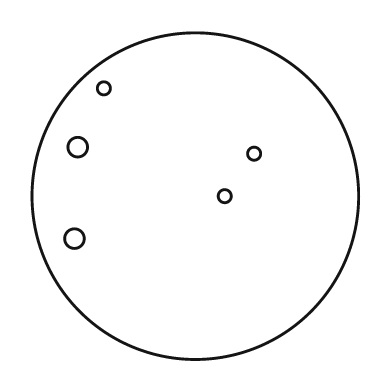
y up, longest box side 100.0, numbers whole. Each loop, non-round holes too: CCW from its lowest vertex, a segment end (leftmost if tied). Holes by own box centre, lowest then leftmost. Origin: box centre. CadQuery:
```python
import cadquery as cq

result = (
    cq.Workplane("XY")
    .moveTo(0.0, 0.0)
    .circle(50.0)
    .moveTo(-37.0, -13.0)
    .circle(3.0)
    .moveTo(9.0, 0.0)
    .circle(2.0)
    .moveTo(18.0, 13.0)
    .circle(2.0)
    .moveTo(-36.0, 15.0)
    .circle(3.0)
    .moveTo(-28.0, 33.0)
    .circle(2.0)
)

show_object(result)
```